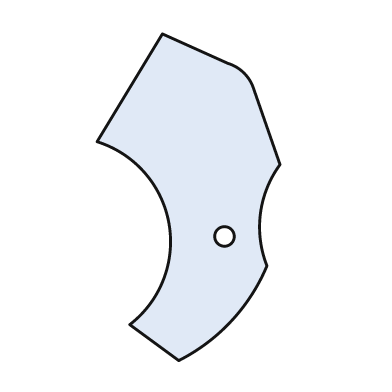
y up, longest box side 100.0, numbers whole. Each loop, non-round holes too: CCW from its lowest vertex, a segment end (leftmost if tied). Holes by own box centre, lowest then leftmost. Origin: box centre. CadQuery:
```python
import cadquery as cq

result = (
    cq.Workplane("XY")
    .moveTo(-3.0, -50.0)
    .threePointArc((13.0, -38.0), (24.0, -21.0))
    .threePointArc((22.0, -5.0), (28.0, 10.0))
    .lineTo(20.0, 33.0)
    .threePointArc((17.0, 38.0), (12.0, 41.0))
    .lineTo(-8.0, 50.0)
    .lineTo(-28.0, 17.0)
    .threePointArc((-6.0, -8.0), (-18.0, -39.0))
    .close()
    .moveTo(11.0, -12.0)
    .circle(3.0)
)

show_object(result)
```